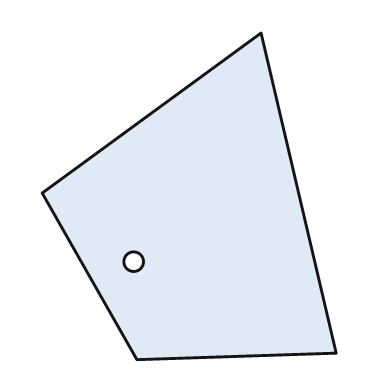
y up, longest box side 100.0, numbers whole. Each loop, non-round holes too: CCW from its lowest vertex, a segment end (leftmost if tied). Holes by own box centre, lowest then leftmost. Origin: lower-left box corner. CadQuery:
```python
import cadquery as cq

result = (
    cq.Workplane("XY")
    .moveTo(29.0, 0.0)
    .lineTo(90.0, 2.0)
    .lineTo(67.0, 100.0)
    .lineTo(0.0, 51.0)
    .close()
    .moveTo(28.0, 30.0)
    .circle(3.0)
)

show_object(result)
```